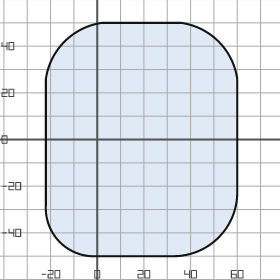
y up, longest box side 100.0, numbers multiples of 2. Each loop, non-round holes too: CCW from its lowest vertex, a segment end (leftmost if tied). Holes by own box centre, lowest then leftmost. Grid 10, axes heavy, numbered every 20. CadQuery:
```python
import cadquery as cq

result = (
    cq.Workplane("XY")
    .moveTo(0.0, -50.0)
    .lineTo(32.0, -50.0)
    .threePointArc((52.0, -42.0), (60.0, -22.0))
    .lineTo(60.0, 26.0)
    .threePointArc((52.0, 42.0), (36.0, 50.0))
    .lineTo(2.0, 50.0)
    .threePointArc((-14.0, 42.0), (-22.0, 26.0))
    .lineTo(-22.0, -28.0)
    .threePointArc((-16.0, -44.0), (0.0, -50.0))
    .close()
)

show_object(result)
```